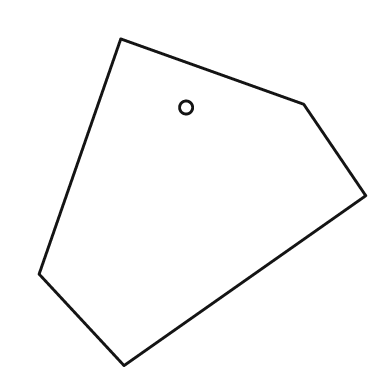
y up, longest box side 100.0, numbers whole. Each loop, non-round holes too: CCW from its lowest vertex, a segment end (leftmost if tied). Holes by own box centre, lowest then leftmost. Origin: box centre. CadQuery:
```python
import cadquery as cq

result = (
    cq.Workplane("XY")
    .moveTo(-24.0, -50.0)
    .lineTo(50.0, 2.0)
    .lineTo(31.0, 30.0)
    .lineTo(-25.0, 50.0)
    .lineTo(-50.0, -22.0)
    .close()
    .moveTo(-5.0, 29.0)
    .circle(2.0)
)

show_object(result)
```